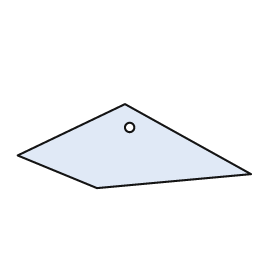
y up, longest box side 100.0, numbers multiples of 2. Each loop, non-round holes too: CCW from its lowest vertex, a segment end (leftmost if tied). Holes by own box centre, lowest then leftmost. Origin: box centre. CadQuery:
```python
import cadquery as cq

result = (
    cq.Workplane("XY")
    .moveTo(-16.0, -18.0)
    .lineTo(50.0, -12.0)
    .lineTo(-4.0, 18.0)
    .lineTo(-50.0, -4.0)
    .close()
    .moveTo(-2.0, 8.0)
    .circle(2.0)
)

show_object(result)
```